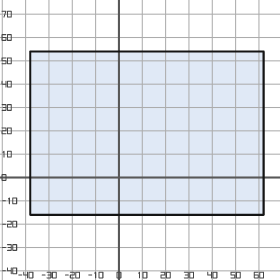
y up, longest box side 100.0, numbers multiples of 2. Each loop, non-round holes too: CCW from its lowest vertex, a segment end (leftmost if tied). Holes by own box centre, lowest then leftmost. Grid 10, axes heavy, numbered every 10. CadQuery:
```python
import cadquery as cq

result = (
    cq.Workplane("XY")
    .moveTo(-38.0, -16.0)
    .lineTo(62.0, -16.0)
    .lineTo(62.0, 54.0)
    .lineTo(-38.0, 54.0)
    .close()
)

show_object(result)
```